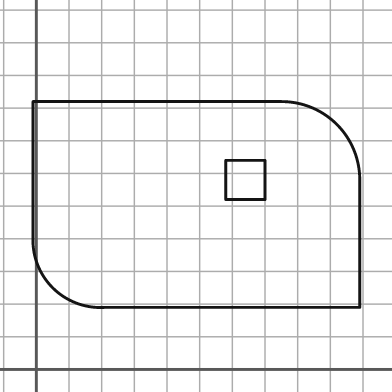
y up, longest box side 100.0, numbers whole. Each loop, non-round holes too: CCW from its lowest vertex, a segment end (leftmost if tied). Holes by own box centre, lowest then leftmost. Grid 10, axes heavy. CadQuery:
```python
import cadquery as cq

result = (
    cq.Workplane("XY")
    .moveTo(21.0, 19.0)
    .lineTo(99.0, 19.0)
    .lineTo(99.0, 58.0)
    .threePointArc((92.0, 75.0), (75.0, 82.0))
    .lineTo(-1.0, 82.0)
    .lineTo(-1.0, 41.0)
    .threePointArc((5.0, 25.0), (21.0, 19.0))
    .close()
    .moveTo(58.0, 52.0)
    .lineTo(70.0, 52.0)
    .lineTo(70.0, 64.0)
    .lineTo(58.0, 64.0)
    .close()
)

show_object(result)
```